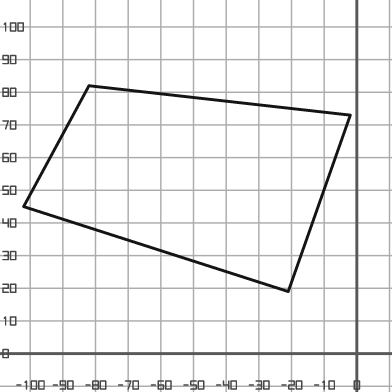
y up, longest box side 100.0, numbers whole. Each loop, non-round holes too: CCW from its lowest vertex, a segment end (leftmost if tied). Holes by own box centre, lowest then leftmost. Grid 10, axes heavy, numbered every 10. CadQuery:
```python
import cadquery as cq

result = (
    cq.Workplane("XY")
    .moveTo(-21.0, 19.0)
    .lineTo(-2.0, 73.0)
    .lineTo(-82.0, 82.0)
    .lineTo(-102.0, 45.0)
    .close()
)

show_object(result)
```